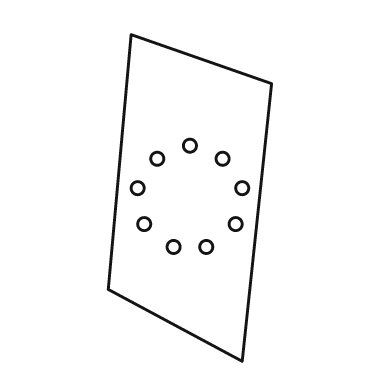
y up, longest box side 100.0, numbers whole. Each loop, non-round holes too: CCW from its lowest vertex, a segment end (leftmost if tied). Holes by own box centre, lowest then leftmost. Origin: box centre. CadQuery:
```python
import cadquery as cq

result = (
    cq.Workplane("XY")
    .moveTo(16.0, -50.0)
    .lineTo(25.0, 35.0)
    .lineTo(-18.0, 50.0)
    .lineTo(-25.0, -28.0)
    .close()
    .moveTo(-5.0, -15.0)
    .circle(2.0)
    .moveTo(5.0, -15.0)
    .circle(2.0)
    .moveTo(-14.0, -8.0)
    .circle(2.0)
    .moveTo(14.0, -8.0)
    .circle(2.0)
    .moveTo(-16.0, 3.0)
    .circle(2.0)
    .moveTo(16.0, 3.0)
    .circle(2.0)
    .moveTo(-10.0, 12.0)
    .circle(2.0)
    .moveTo(10.0, 12.0)
    .circle(2.0)
    .moveTo(0.0, 16.0)
    .circle(2.0)
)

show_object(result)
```